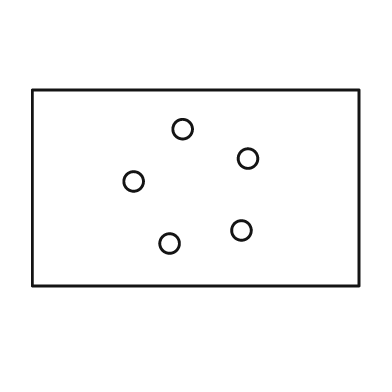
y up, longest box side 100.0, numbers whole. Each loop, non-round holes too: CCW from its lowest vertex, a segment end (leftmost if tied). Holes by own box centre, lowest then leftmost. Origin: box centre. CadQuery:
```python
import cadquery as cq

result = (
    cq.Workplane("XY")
    .moveTo(-50.0, -30.0)
    .lineTo(50.0, -30.0)
    .lineTo(50.0, 30.0)
    .lineTo(-50.0, 30.0)
    .close()
    .moveTo(-8.0, -17.0)
    .circle(3.0)
    .moveTo(14.0, -13.0)
    .circle(3.0)
    .moveTo(-19.0, 2.0)
    .circle(3.0)
    .moveTo(16.0, 9.0)
    .circle(3.0)
    .moveTo(-4.0, 18.0)
    .circle(3.0)
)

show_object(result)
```